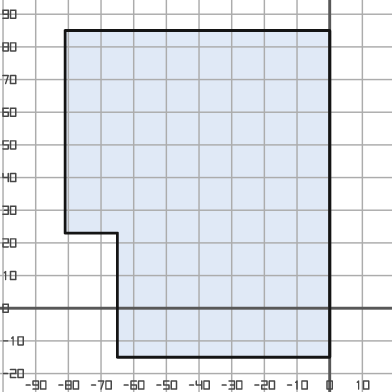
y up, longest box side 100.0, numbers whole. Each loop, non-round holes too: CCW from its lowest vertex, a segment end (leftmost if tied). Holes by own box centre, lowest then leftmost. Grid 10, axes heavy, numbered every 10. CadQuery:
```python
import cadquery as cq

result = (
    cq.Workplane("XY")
    .moveTo(-65.0, -15.0)
    .lineTo(0.0, -15.0)
    .lineTo(0.0, 85.0)
    .lineTo(-81.0, 85.0)
    .lineTo(-81.0, 23.0)
    .lineTo(-65.0, 23.0)
    .close()
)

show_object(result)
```